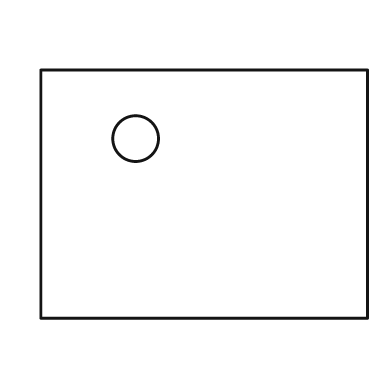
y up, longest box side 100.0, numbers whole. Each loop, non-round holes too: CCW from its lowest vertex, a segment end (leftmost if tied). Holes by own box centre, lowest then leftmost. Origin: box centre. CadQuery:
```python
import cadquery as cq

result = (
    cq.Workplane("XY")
    .moveTo(-50.0, -38.0)
    .lineTo(50.0, -38.0)
    .lineTo(50.0, 38.0)
    .lineTo(-50.0, 38.0)
    .close()
    .moveTo(-21.0, 17.0)
    .circle(7.0)
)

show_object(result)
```